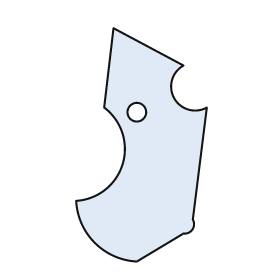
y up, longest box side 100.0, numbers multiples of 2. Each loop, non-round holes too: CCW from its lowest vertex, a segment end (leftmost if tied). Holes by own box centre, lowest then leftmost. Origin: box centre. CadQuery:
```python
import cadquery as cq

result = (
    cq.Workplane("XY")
    .moveTo(-2.0, -50.0)
    .lineTo(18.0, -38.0)
    .threePointArc((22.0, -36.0), (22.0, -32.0))
    .lineTo(28.0, 16.0)
    .threePointArc((14.0, 20.0), (18.0, 34.0))
    .lineTo(-12.0, 50.0)
    .lineTo(-16.0, 16.0)
    .threePointArc((-8.0, -8.0), (-28.0, -24.0))
    .threePointArc((-20.0, -42.0), (-2.0, -50.0))
    .close()
    .moveTo(-2.0, 14.0)
    .circle(4.0)
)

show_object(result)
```